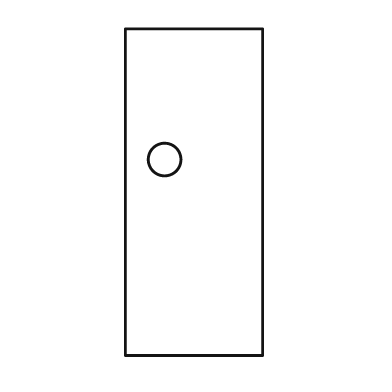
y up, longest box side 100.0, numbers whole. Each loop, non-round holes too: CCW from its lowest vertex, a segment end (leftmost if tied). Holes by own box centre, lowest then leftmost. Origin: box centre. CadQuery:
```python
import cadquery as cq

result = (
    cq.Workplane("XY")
    .moveTo(-21.0, -50.0)
    .lineTo(21.0, -50.0)
    .lineTo(21.0, 50.0)
    .lineTo(-21.0, 50.0)
    .close()
    .moveTo(-9.0, 10.0)
    .circle(5.0)
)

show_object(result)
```